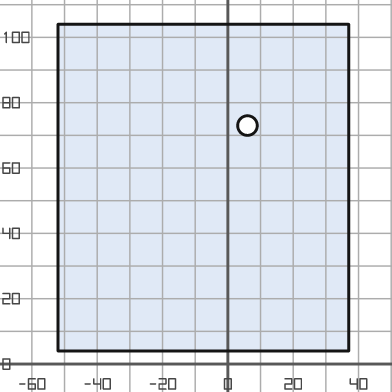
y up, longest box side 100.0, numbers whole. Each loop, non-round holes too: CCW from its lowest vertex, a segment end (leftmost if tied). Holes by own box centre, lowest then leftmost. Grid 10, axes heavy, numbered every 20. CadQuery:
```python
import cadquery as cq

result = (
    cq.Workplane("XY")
    .moveTo(-52.0, 4.0)
    .lineTo(37.0, 4.0)
    .lineTo(37.0, 104.0)
    .lineTo(-52.0, 104.0)
    .close()
    .moveTo(6.0, 73.0)
    .circle(3.0)
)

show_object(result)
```